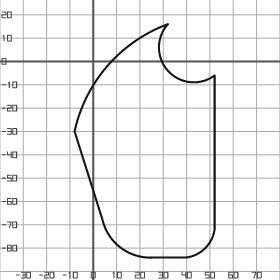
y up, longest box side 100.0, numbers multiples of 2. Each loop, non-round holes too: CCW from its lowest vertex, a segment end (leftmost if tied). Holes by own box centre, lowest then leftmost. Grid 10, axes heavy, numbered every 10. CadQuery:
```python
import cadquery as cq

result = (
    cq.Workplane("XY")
    .moveTo(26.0, -84.0)
    .lineTo(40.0, -84.0)
    .threePointArc((48.0, -80.0), (52.0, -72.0))
    .lineTo(52.0, -6.0)
    .threePointArc((32.0, -4.0), (32.0, 16.0))
    .threePointArc((6.0, -2.0), (-8.0, -30.0))
    .lineTo(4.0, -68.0)
    .threePointArc((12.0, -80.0), (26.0, -84.0))
    .close()
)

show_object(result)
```